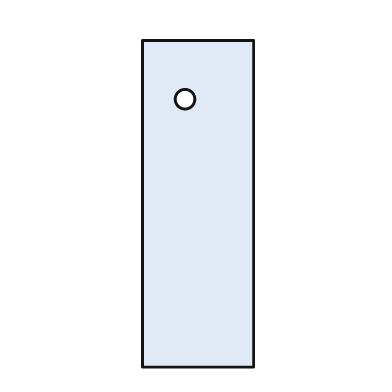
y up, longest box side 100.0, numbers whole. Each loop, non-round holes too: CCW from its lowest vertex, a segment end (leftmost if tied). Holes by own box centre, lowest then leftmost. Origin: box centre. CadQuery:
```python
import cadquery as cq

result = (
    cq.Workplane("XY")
    .moveTo(-17.0, -50.0)
    .lineTo(17.0, -50.0)
    .lineTo(17.0, 50.0)
    .lineTo(-17.0, 50.0)
    .close()
    .moveTo(-4.0, 32.0)
    .circle(3.0)
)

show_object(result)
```